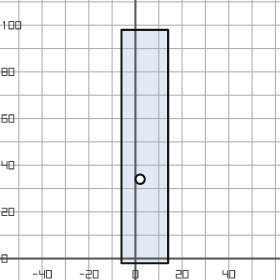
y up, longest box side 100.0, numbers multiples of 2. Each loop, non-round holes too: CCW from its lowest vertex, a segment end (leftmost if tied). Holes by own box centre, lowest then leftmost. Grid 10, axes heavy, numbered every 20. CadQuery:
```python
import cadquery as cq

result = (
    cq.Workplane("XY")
    .moveTo(-6.0, -2.0)
    .lineTo(14.0, -2.0)
    .lineTo(14.0, 98.0)
    .lineTo(-6.0, 98.0)
    .close()
    .moveTo(2.0, 34.0)
    .circle(2.0)
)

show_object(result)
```